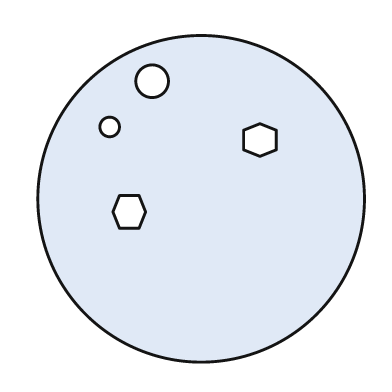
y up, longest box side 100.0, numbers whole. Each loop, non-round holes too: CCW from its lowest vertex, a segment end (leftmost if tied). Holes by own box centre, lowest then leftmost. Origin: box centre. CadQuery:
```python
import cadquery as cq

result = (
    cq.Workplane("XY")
    .moveTo(0.0, 0.0)
    .circle(50.0)
    .moveTo(-25.0, -9.0)
    .lineTo(-19.0, -9.0)
    .lineTo(-17.0, -4.0)
    .lineTo(-19.0, 1.0)
    .lineTo(-25.0, 1.0)
    .lineTo(-27.0, -4.0)
    .close()
    .moveTo(18.0, 13.0)
    .lineTo(23.0, 15.0)
    .lineTo(23.0, 21.0)
    .lineTo(18.0, 23.0)
    .lineTo(13.0, 21.0)
    .lineTo(13.0, 15.0)
    .close()
    .moveTo(-28.0, 22.0)
    .circle(3.0)
    .moveTo(-15.0, 36.0)
    .circle(5.0)
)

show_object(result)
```